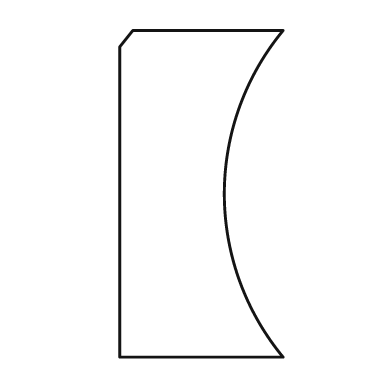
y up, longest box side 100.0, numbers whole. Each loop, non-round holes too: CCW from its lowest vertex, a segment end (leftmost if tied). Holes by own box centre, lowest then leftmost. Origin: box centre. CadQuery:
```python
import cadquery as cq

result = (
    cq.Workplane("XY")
    .moveTo(-25.0, -50.0)
    .lineTo(25.0, -50.0)
    .threePointArc((7.0, 0.0), (25.0, 50.0))
    .lineTo(-21.0, 50.0)
    .lineTo(-25.0, 45.0)
    .close()
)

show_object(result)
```